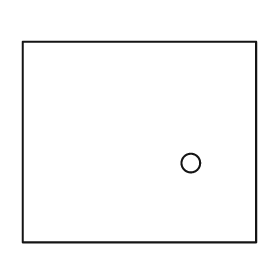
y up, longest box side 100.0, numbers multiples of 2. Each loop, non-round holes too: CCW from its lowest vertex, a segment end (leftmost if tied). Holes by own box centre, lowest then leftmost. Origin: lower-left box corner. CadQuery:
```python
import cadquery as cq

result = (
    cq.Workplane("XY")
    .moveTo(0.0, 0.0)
    .lineTo(100.0, 0.0)
    .lineTo(100.0, 86.0)
    .lineTo(0.0, 86.0)
    .close()
    .moveTo(72.0, 34.0)
    .circle(4.0)
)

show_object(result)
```